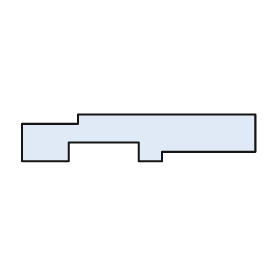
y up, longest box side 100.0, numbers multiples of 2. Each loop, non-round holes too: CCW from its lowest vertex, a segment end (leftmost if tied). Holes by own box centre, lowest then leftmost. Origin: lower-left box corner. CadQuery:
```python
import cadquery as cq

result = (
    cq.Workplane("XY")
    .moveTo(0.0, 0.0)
    .lineTo(20.0, 0.0)
    .lineTo(20.0, 8.0)
    .lineTo(50.0, 8.0)
    .lineTo(50.0, 0.0)
    .lineTo(60.0, 0.0)
    .lineTo(60.0, 4.0)
    .lineTo(100.0, 4.0)
    .lineTo(100.0, 20.0)
    .lineTo(24.0, 20.0)
    .lineTo(24.0, 16.0)
    .lineTo(0.0, 16.0)
    .close()
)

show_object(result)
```